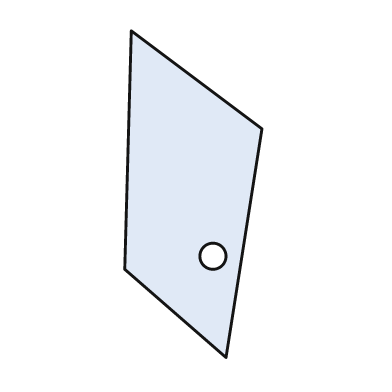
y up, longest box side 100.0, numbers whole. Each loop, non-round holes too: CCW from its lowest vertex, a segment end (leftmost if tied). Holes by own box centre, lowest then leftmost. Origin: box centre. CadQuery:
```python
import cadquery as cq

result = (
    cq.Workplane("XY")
    .moveTo(10.0, -50.0)
    .lineTo(21.0, 20.0)
    .lineTo(-19.0, 50.0)
    .lineTo(-21.0, -23.0)
    .close()
    .moveTo(6.0, -19.0)
    .circle(4.0)
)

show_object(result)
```